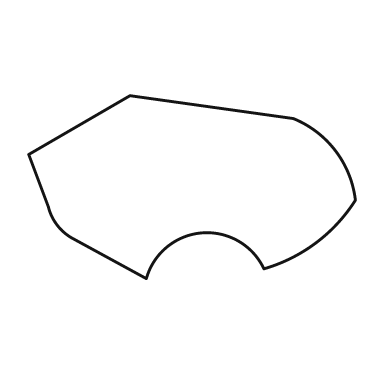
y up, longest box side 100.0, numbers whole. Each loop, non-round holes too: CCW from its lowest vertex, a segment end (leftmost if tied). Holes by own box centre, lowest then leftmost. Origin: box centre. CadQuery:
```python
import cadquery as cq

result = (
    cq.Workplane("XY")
    .moveTo(-14.0, -28.0)
    .threePointArc((3.0, -14.0), (22.0, -25.0))
    .threePointArc((38.0, -17.0), (50.0, -4.0))
    .threePointArc((44.0, 11.0), (31.0, 21.0))
    .lineTo(-19.0, 28.0)
    .lineTo(-50.0, 10.0)
    .lineTo(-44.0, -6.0)
    .threePointArc((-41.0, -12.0), (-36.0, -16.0))
    .close()
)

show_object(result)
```